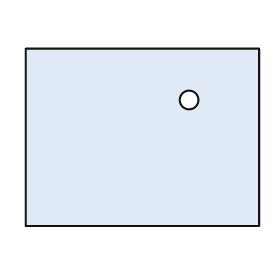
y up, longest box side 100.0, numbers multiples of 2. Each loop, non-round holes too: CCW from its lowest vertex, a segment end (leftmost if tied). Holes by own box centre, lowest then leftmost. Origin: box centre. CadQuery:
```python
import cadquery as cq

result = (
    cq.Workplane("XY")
    .moveTo(-50.0, -38.0)
    .lineTo(50.0, -38.0)
    .lineTo(50.0, 38.0)
    .lineTo(-50.0, 38.0)
    .close()
    .moveTo(20.0, 16.0)
    .circle(4.0)
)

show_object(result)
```